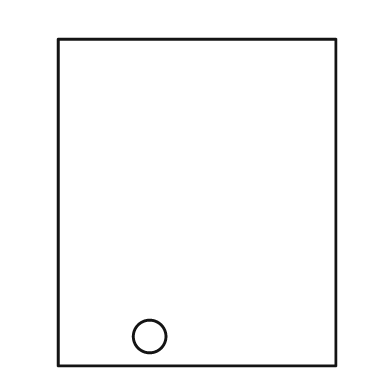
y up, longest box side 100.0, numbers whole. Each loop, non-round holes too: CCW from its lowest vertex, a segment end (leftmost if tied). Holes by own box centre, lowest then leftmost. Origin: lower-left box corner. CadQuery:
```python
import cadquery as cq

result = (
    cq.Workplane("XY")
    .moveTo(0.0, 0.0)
    .lineTo(85.0, 0.0)
    .lineTo(85.0, 100.0)
    .lineTo(0.0, 100.0)
    .close()
    .moveTo(28.0, 9.0)
    .circle(5.0)
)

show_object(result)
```